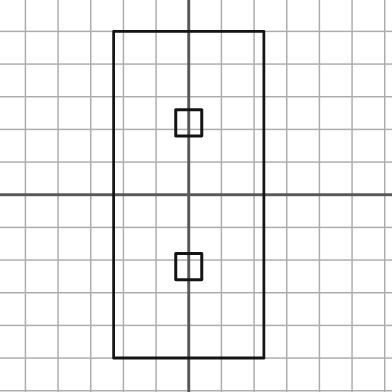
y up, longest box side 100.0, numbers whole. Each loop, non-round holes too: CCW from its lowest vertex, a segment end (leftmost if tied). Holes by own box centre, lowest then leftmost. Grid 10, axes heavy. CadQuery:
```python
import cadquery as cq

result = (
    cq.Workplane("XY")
    .moveTo(-23.0, -50.0)
    .lineTo(23.0, -50.0)
    .lineTo(23.0, 50.0)
    .lineTo(-23.0, 50.0)
    .close()
    .moveTo(-4.0, -26.0)
    .lineTo(4.0, -26.0)
    .lineTo(4.0, -18.0)
    .lineTo(-4.0, -18.0)
    .close()
    .moveTo(-4.0, 18.0)
    .lineTo(4.0, 18.0)
    .lineTo(4.0, 26.0)
    .lineTo(-4.0, 26.0)
    .close()
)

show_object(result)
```